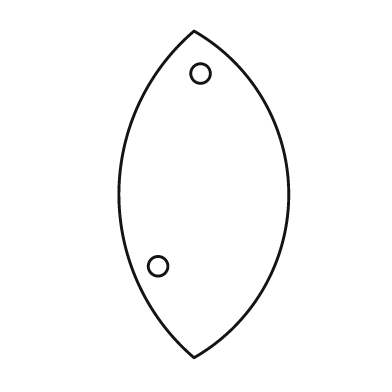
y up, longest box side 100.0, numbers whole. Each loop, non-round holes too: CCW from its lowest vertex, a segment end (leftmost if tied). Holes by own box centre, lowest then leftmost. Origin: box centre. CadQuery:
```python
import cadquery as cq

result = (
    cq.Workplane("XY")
    .moveTo(-3.0, -50.0)
    .threePointArc((26.0, 0.0), (-3.0, 50.0))
    .threePointArc((-26.0, 0.0), (-3.0, -50.0))
    .close()
    .moveTo(-14.0, -22.0)
    .circle(3.0)
    .moveTo(-1.0, 37.0)
    .circle(3.0)
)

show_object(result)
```